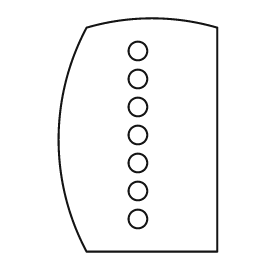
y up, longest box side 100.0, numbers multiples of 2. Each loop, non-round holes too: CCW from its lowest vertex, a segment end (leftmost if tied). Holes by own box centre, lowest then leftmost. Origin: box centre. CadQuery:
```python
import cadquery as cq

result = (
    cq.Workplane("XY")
    .moveTo(-22.0, -50.0)
    .lineTo(34.0, -50.0)
    .lineTo(34.0, 46.0)
    .threePointArc((6.0, 50.0), (-22.0, 46.0))
    .threePointArc((-34.0, -2.0), (-22.0, -50.0))
    .close()
    .moveTo(0.0, -36.0)
    .circle(4.0)
    .moveTo(0.0, -24.0)
    .circle(4.0)
    .moveTo(0.0, -12.0)
    .circle(4.0)
    .moveTo(0.0, 0.0)
    .circle(4.0)
    .moveTo(0.0, 12.0)
    .circle(4.0)
    .moveTo(0.0, 24.0)
    .circle(4.0)
    .moveTo(0.0, 36.0)
    .circle(4.0)
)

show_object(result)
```